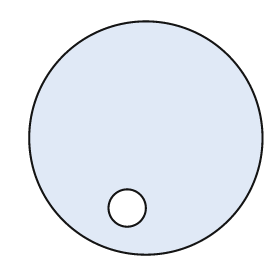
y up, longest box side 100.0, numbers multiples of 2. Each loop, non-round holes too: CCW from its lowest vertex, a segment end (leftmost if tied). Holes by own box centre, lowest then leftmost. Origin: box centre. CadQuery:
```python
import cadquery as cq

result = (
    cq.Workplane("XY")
    .moveTo(0.0, 0.0)
    .circle(50.0)
    .moveTo(-8.0, -30.0)
    .circle(8.0)
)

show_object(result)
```